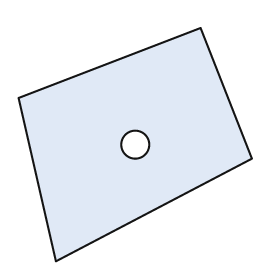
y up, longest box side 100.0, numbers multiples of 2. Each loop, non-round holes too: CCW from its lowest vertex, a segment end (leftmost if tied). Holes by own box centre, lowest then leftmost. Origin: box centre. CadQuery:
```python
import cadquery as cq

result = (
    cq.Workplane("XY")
    .moveTo(-34.0, -50.0)
    .lineTo(50.0, -6.0)
    .lineTo(28.0, 50.0)
    .lineTo(-50.0, 20.0)
    .close()
    .moveTo(0.0, 0.0)
    .circle(6.0)
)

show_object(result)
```